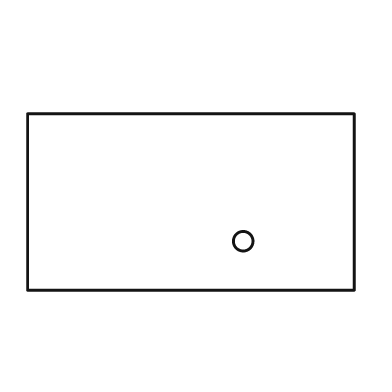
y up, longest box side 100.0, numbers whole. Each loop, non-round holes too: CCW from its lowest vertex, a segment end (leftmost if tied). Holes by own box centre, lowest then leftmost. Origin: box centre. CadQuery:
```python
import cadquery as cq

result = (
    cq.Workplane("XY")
    .moveTo(-50.0, -27.0)
    .lineTo(50.0, -27.0)
    .lineTo(50.0, 27.0)
    .lineTo(-50.0, 27.0)
    .close()
    .moveTo(16.0, -12.0)
    .circle(3.0)
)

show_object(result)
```